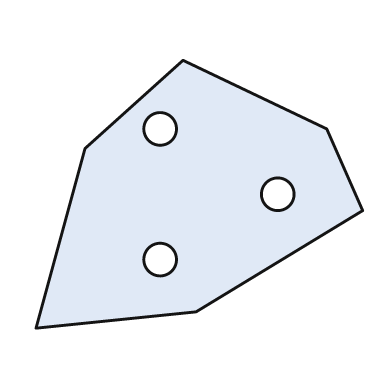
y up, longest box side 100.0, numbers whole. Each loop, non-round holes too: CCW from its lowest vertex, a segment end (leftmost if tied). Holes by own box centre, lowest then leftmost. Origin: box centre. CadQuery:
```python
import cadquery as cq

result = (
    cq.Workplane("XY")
    .moveTo(-50.0, -41.0)
    .lineTo(-1.0, -36.0)
    .lineTo(50.0, -5.0)
    .lineTo(39.0, 20.0)
    .lineTo(-5.0, 41.0)
    .lineTo(-35.0, 14.0)
    .close()
    .moveTo(-12.0, -20.0)
    .circle(5.0)
    .moveTo(24.0, 0.0)
    .circle(5.0)
    .moveTo(-12.0, 20.0)
    .circle(5.0)
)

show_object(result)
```